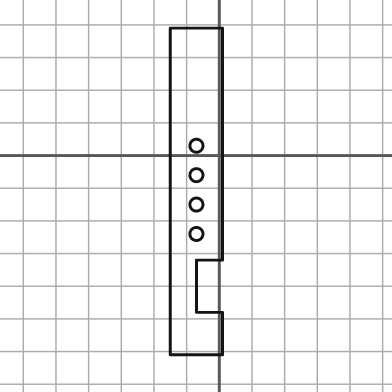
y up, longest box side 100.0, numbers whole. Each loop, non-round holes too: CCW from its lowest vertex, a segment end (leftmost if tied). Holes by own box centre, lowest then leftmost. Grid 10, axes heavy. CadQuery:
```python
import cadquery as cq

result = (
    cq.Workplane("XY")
    .moveTo(-15.0, -61.0)
    .lineTo(1.0, -61.0)
    .lineTo(1.0, -48.0)
    .lineTo(-7.0, -48.0)
    .lineTo(-7.0, -32.0)
    .lineTo(1.0, -32.0)
    .lineTo(1.0, 39.0)
    .lineTo(-15.0, 39.0)
    .close()
    .moveTo(-7.0, -24.0)
    .circle(2.0)
    .moveTo(-7.0, -15.0)
    .circle(2.0)
    .moveTo(-7.0, -6.0)
    .circle(2.0)
    .moveTo(-7.0, 3.0)
    .circle(2.0)
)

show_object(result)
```